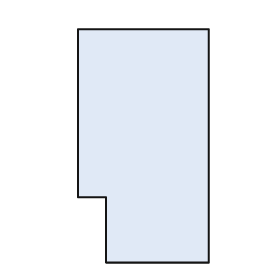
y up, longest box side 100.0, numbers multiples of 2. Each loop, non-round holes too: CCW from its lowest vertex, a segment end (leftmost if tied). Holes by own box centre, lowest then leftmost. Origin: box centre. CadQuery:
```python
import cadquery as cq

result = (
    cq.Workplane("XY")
    .moveTo(-16.0, -50.0)
    .lineTo(28.0, -50.0)
    .lineTo(28.0, 50.0)
    .lineTo(-28.0, 50.0)
    .lineTo(-28.0, -22.0)
    .lineTo(-16.0, -22.0)
    .close()
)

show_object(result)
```